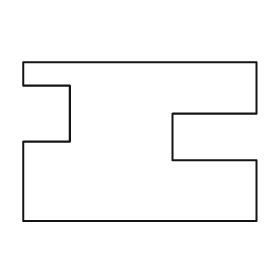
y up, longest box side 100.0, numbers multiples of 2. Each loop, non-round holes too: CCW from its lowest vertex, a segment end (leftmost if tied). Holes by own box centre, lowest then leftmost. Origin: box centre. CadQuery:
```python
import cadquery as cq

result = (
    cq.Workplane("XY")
    .moveTo(-50.0, -34.0)
    .lineTo(50.0, -34.0)
    .lineTo(50.0, -8.0)
    .lineTo(14.0, -8.0)
    .lineTo(14.0, 12.0)
    .lineTo(50.0, 12.0)
    .lineTo(50.0, 34.0)
    .lineTo(-50.0, 34.0)
    .lineTo(-50.0, 24.0)
    .lineTo(-30.0, 24.0)
    .lineTo(-30.0, 0.0)
    .lineTo(-50.0, 0.0)
    .close()
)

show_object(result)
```